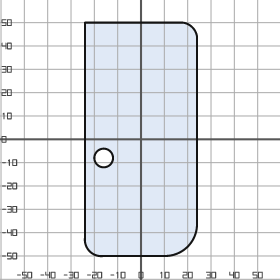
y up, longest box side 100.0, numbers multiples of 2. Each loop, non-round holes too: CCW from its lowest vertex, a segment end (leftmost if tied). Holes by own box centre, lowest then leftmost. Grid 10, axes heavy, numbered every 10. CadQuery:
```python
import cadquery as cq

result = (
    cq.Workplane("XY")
    .moveTo(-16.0, -50.0)
    .lineTo(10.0, -50.0)
    .threePointArc((20.0, -46.0), (24.0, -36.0))
    .lineTo(24.0, 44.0)
    .threePointArc((22.0, 48.0), (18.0, 50.0))
    .lineTo(-24.0, 50.0)
    .lineTo(-24.0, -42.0)
    .threePointArc((-22.0, -48.0), (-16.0, -50.0))
    .close()
    .moveTo(-16.0, -8.0)
    .circle(4.0)
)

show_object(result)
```